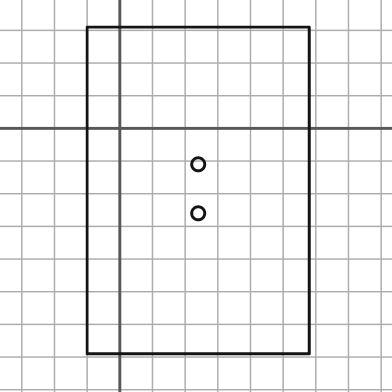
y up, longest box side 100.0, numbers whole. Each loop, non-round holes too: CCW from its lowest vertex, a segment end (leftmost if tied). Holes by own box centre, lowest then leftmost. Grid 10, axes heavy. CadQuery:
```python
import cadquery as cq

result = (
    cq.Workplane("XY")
    .moveTo(-10.0, -69.0)
    .lineTo(58.0, -69.0)
    .lineTo(58.0, 31.0)
    .lineTo(-10.0, 31.0)
    .close()
    .moveTo(24.0, -26.0)
    .circle(2.0)
    .moveTo(24.0, -11.0)
    .circle(2.0)
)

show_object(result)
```